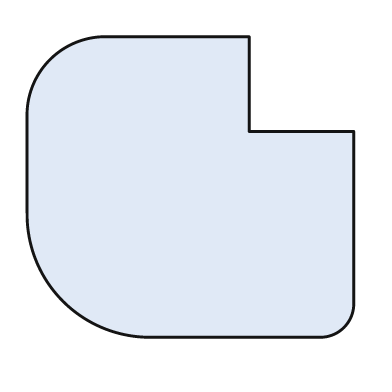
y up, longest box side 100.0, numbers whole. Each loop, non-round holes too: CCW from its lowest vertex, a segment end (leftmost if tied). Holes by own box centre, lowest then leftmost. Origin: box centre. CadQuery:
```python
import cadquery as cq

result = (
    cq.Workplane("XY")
    .moveTo(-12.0, -46.0)
    .lineTo(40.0, -46.0)
    .threePointArc((47.0, -43.0), (50.0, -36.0))
    .lineTo(50.0, 17.0)
    .lineTo(18.0, 17.0)
    .lineTo(18.0, 46.0)
    .lineTo(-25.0, 46.0)
    .threePointArc((-43.0, 39.0), (-50.0, 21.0))
    .lineTo(-50.0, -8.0)
    .threePointArc((-39.0, -35.0), (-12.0, -46.0))
    .close()
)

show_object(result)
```